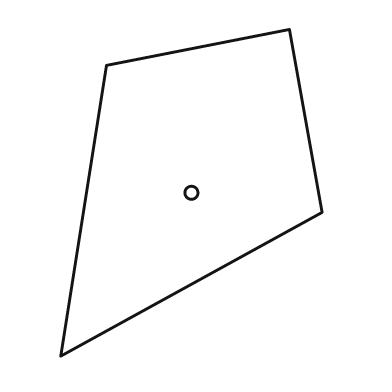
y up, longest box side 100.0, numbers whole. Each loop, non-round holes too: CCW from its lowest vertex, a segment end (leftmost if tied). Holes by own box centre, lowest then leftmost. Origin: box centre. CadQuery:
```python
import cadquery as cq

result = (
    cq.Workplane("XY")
    .moveTo(-40.0, -50.0)
    .lineTo(40.0, -6.0)
    .lineTo(30.0, 50.0)
    .lineTo(-26.0, 39.0)
    .close()
    .moveTo(0.0, 0.0)
    .circle(2.0)
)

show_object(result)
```